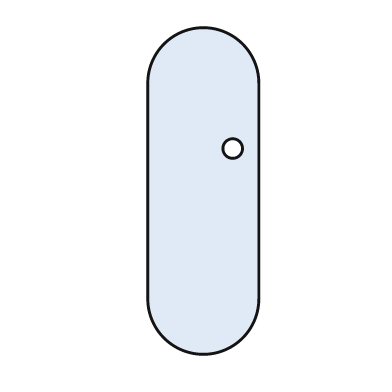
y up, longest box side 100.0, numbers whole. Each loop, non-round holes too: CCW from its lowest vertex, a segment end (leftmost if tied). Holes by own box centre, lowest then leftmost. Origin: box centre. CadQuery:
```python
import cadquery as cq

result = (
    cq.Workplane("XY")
    .moveTo(-17.0, -33.0)
    .threePointArc((0.0, -50.0), (17.0, -33.0))
    .lineTo(17.0, 33.0)
    .threePointArc((0.0, 50.0), (-17.0, 33.0))
    .close()
    .moveTo(9.0, 13.0)
    .circle(3.0)
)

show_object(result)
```